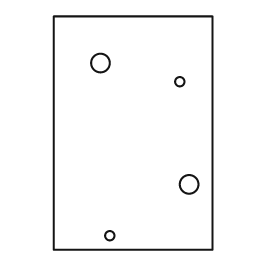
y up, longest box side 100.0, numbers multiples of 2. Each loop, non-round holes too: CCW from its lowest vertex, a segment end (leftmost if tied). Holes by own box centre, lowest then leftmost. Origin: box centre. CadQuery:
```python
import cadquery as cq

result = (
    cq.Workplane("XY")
    .moveTo(-34.0, -50.0)
    .lineTo(34.0, -50.0)
    .lineTo(34.0, 50.0)
    .lineTo(-34.0, 50.0)
    .close()
    .moveTo(-10.0, -44.0)
    .circle(2.0)
    .moveTo(24.0, -22.0)
    .circle(4.0)
    .moveTo(20.0, 22.0)
    .circle(2.0)
    .moveTo(-14.0, 30.0)
    .circle(4.0)
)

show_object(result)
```